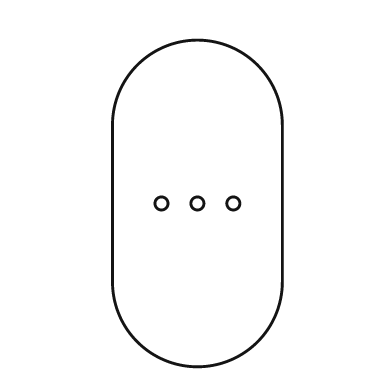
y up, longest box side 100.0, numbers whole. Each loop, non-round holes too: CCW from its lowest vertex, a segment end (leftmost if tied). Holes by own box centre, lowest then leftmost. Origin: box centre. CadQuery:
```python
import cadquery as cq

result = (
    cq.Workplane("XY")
    .moveTo(-26.0, -24.0)
    .threePointArc((0.0, -50.0), (26.0, -24.0))
    .lineTo(26.0, 24.0)
    .threePointArc((0.0, 50.0), (-26.0, 24.0))
    .close()
    .moveTo(-11.0, 0.0)
    .circle(2.0)
    .moveTo(0.0, 0.0)
    .circle(2.0)
    .moveTo(11.0, 0.0)
    .circle(2.0)
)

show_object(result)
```